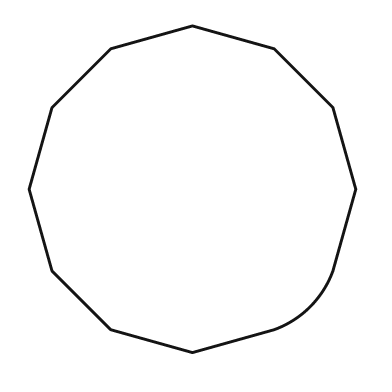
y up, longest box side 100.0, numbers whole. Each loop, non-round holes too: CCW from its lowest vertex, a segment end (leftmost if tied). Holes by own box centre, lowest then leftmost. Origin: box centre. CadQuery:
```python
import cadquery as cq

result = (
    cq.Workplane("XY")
    .moveTo(0.0, -50.0)
    .lineTo(25.0, -43.0)
    .threePointArc((36.0, -36.0), (43.0, -25.0))
    .lineTo(50.0, 0.0)
    .lineTo(43.0, 25.0)
    .lineTo(25.0, 43.0)
    .lineTo(0.0, 50.0)
    .lineTo(-25.0, 43.0)
    .lineTo(-43.0, 25.0)
    .lineTo(-50.0, 0.0)
    .lineTo(-43.0, -25.0)
    .lineTo(-25.0, -43.0)
    .close()
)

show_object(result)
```